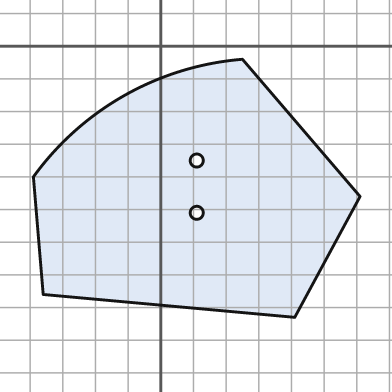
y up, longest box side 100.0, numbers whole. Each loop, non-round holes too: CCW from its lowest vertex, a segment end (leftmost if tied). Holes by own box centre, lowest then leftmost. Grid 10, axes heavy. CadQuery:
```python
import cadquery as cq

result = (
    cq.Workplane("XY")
    .moveTo(41.0, -83.0)
    .lineTo(61.0, -46.0)
    .lineTo(25.0, -4.0)
    .threePointArc((-11.0, -15.0), (-39.0, -40.0))
    .lineTo(-36.0, -76.0)
    .close()
    .moveTo(11.0, -51.0)
    .circle(2.0)
    .moveTo(11.0, -35.0)
    .circle(2.0)
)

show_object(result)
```